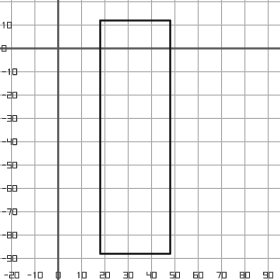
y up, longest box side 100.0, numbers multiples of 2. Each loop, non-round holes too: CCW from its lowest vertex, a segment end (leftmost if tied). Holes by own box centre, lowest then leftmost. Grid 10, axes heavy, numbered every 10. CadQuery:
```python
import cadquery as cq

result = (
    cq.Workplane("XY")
    .moveTo(18.0, -88.0)
    .lineTo(48.0, -88.0)
    .lineTo(48.0, 12.0)
    .lineTo(18.0, 12.0)
    .close()
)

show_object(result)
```